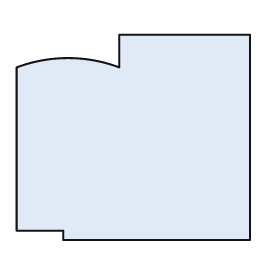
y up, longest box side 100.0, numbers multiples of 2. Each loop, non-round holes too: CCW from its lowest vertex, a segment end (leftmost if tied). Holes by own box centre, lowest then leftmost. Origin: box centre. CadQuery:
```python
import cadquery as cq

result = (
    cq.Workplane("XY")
    .moveTo(-30.0, -44.0)
    .lineTo(50.0, -44.0)
    .lineTo(50.0, 44.0)
    .lineTo(-6.0, 44.0)
    .lineTo(-6.0, 30.0)
    .threePointArc((-28.0, 34.0), (-50.0, 30.0))
    .lineTo(-50.0, -40.0)
    .lineTo(-30.0, -40.0)
    .close()
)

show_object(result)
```